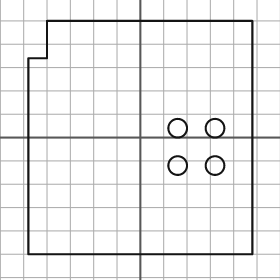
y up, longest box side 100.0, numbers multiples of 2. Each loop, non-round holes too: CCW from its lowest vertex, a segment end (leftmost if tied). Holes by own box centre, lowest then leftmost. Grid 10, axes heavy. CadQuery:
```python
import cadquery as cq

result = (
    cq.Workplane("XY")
    .moveTo(-48.0, -50.0)
    .lineTo(48.0, -50.0)
    .lineTo(48.0, 50.0)
    .lineTo(-40.0, 50.0)
    .lineTo(-40.0, 34.0)
    .lineTo(-48.0, 34.0)
    .close()
    .moveTo(16.0, -12.0)
    .circle(4.0)
    .moveTo(32.0, -12.0)
    .circle(4.0)
    .moveTo(16.0, 4.0)
    .circle(4.0)
    .moveTo(32.0, 4.0)
    .circle(4.0)
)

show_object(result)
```